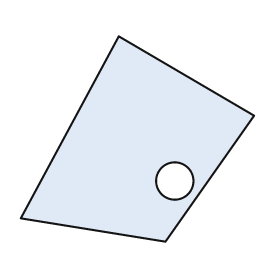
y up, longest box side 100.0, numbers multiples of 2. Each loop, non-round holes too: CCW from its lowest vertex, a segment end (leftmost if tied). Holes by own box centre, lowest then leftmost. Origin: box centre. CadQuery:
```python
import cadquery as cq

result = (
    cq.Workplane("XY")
    .moveTo(12.0, -44.0)
    .lineTo(50.0, 10.0)
    .lineTo(-8.0, 44.0)
    .lineTo(-50.0, -34.0)
    .close()
    .moveTo(16.0, -18.0)
    .circle(8.0)
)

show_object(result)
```